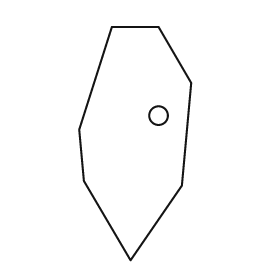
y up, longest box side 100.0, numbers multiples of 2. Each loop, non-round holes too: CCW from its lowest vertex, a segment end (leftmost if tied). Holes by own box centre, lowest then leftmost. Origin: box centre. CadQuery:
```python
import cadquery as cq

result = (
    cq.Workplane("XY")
    .moveTo(-2.0, -50.0)
    .lineTo(20.0, -18.0)
    .lineTo(24.0, 26.0)
    .lineTo(10.0, 50.0)
    .lineTo(-10.0, 50.0)
    .lineTo(-24.0, 6.0)
    .lineTo(-22.0, -16.0)
    .close()
    .moveTo(10.0, 12.0)
    .circle(4.0)
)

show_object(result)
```